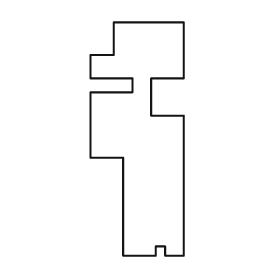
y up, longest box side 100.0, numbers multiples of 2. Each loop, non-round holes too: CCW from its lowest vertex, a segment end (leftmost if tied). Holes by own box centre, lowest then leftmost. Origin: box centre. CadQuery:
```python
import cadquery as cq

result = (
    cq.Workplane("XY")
    .moveTo(-6.0, -50.0)
    .lineTo(8.0, -50.0)
    .lineTo(8.0, -46.0)
    .lineTo(12.0, -46.0)
    .lineTo(12.0, -50.0)
    .lineTo(20.0, -50.0)
    .lineTo(20.0, 10.0)
    .lineTo(6.0, 10.0)
    .lineTo(6.0, 26.0)
    .lineTo(20.0, 26.0)
    .lineTo(20.0, 50.0)
    .lineTo(-10.0, 50.0)
    .lineTo(-10.0, 36.0)
    .lineTo(-20.0, 36.0)
    .lineTo(-20.0, 26.0)
    .lineTo(-2.0, 26.0)
    .lineTo(-2.0, 20.0)
    .lineTo(-20.0, 20.0)
    .lineTo(-20.0, -8.0)
    .lineTo(-6.0, -8.0)
    .close()
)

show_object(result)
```